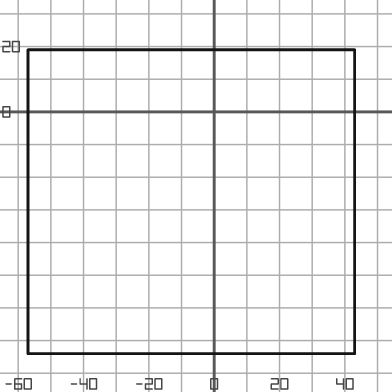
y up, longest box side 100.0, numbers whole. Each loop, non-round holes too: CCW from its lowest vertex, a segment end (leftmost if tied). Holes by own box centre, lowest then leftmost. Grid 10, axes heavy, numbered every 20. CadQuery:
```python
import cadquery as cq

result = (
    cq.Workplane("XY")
    .moveTo(-57.0, -74.0)
    .lineTo(43.0, -74.0)
    .lineTo(43.0, 19.0)
    .lineTo(-57.0, 19.0)
    .close()
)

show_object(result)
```